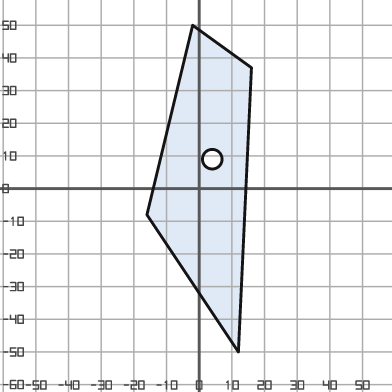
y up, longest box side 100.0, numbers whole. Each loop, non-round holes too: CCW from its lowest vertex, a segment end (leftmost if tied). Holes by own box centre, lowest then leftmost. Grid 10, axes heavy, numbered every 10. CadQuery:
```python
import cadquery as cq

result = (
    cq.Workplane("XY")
    .moveTo(12.0, -50.0)
    .lineTo(16.0, 37.0)
    .lineTo(-2.0, 50.0)
    .lineTo(-16.0, -8.0)
    .close()
    .moveTo(4.0, 9.0)
    .circle(3.0)
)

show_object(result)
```